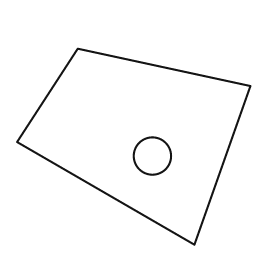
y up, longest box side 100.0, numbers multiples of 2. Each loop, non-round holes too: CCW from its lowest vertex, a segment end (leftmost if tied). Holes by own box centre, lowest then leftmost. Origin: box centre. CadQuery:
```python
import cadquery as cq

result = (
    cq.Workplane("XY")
    .moveTo(26.0, -42.0)
    .lineTo(50.0, 26.0)
    .lineTo(-24.0, 42.0)
    .lineTo(-50.0, 2.0)
    .close()
    .moveTo(8.0, -4.0)
    .circle(8.0)
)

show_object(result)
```